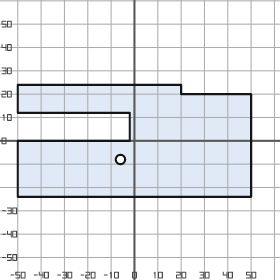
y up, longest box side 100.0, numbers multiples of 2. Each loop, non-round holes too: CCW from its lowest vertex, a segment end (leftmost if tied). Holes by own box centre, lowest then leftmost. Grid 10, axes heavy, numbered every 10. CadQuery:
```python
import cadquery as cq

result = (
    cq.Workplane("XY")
    .moveTo(-50.0, -24.0)
    .lineTo(50.0, -24.0)
    .lineTo(50.0, 20.0)
    .lineTo(20.0, 20.0)
    .lineTo(20.0, 24.0)
    .lineTo(-50.0, 24.0)
    .lineTo(-50.0, 12.0)
    .lineTo(-2.0, 12.0)
    .lineTo(-2.0, 0.0)
    .lineTo(-50.0, 0.0)
    .close()
    .moveTo(-6.0, -8.0)
    .circle(2.0)
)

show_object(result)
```